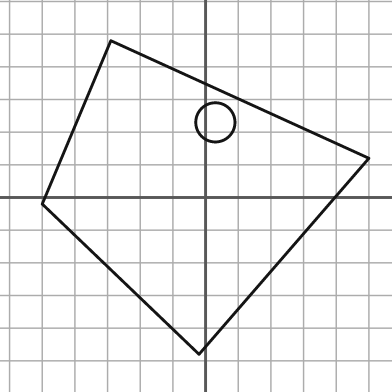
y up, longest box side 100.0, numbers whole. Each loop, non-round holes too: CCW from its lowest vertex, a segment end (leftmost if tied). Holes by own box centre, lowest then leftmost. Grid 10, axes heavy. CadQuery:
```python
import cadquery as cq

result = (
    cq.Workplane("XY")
    .moveTo(-2.0, -48.0)
    .lineTo(50.0, 12.0)
    .lineTo(-29.0, 48.0)
    .lineTo(-50.0, -2.0)
    .close()
    .moveTo(3.0, 23.0)
    .circle(6.0)
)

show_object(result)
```